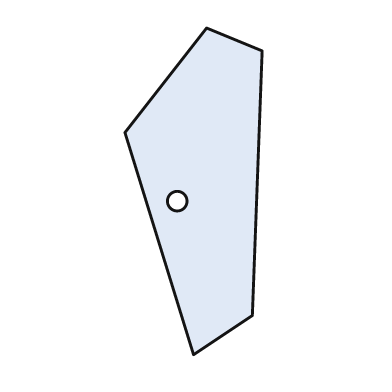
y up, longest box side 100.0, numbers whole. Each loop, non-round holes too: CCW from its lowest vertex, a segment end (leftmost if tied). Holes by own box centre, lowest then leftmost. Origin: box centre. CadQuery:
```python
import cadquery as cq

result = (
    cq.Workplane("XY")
    .moveTo(0.0, -50.0)
    .lineTo(18.0, -38.0)
    .lineTo(21.0, 43.0)
    .lineTo(4.0, 50.0)
    .lineTo(-21.0, 18.0)
    .close()
    .moveTo(-5.0, -3.0)
    .circle(3.0)
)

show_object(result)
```